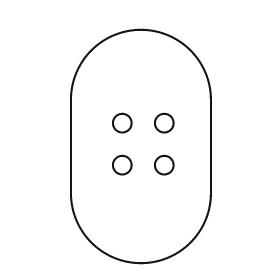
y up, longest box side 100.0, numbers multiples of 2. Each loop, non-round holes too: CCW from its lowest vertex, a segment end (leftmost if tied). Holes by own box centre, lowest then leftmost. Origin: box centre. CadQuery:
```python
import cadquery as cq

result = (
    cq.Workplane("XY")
    .moveTo(-30.0, -20.0)
    .threePointArc((0.0, -50.0), (30.0, -20.0))
    .lineTo(30.0, 20.0)
    .threePointArc((0.0, 50.0), (-30.0, 20.0))
    .close()
    .moveTo(-8.0, -8.0)
    .circle(4.0)
    .moveTo(10.0, -8.0)
    .circle(4.0)
    .moveTo(-8.0, 10.0)
    .circle(4.0)
    .moveTo(10.0, 10.0)
    .circle(4.0)
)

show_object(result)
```